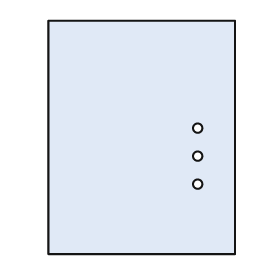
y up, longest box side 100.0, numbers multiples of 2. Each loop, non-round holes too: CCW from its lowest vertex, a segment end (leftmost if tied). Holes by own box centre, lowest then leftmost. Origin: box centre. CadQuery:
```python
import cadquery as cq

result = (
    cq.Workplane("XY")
    .moveTo(-40.0, -50.0)
    .lineTo(40.0, -50.0)
    .lineTo(40.0, 50.0)
    .lineTo(-40.0, 50.0)
    .close()
    .moveTo(24.0, -20.0)
    .circle(2.0)
    .moveTo(24.0, -8.0)
    .circle(2.0)
    .moveTo(24.0, 4.0)
    .circle(2.0)
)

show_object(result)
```